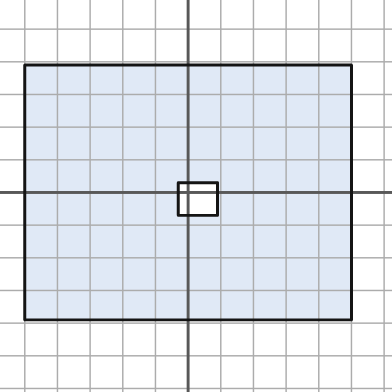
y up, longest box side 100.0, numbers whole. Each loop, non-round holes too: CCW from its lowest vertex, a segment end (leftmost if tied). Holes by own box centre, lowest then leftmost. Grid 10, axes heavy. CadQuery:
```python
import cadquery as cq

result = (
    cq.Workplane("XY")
    .moveTo(-50.0, -39.0)
    .lineTo(50.0, -39.0)
    .lineTo(50.0, 39.0)
    .lineTo(-50.0, 39.0)
    .close()
    .moveTo(-3.0, -7.0)
    .lineTo(9.0, -7.0)
    .lineTo(9.0, 3.0)
    .lineTo(-3.0, 3.0)
    .close()
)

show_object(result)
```